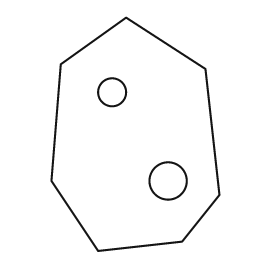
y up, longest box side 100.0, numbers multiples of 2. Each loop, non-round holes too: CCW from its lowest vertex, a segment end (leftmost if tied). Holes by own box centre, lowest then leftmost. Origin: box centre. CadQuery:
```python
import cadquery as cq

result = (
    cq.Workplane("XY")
    .moveTo(-16.0, -50.0)
    .lineTo(20.0, -46.0)
    .lineTo(36.0, -26.0)
    .lineTo(30.0, 28.0)
    .lineTo(-4.0, 50.0)
    .lineTo(-32.0, 30.0)
    .lineTo(-36.0, -20.0)
    .close()
    .moveTo(14.0, -20.0)
    .circle(8.0)
    .moveTo(-10.0, 18.0)
    .circle(6.0)
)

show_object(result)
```